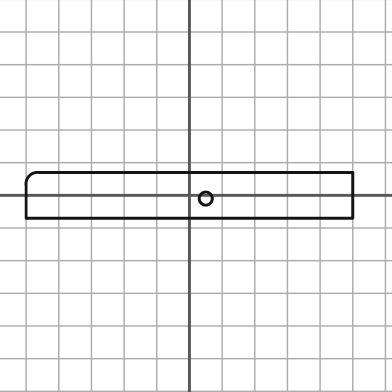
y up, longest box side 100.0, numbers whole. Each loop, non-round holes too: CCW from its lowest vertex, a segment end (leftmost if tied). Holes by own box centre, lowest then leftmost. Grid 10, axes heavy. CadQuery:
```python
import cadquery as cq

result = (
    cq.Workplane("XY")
    .moveTo(-50.0, -7.0)
    .lineTo(50.0, -7.0)
    .lineTo(50.0, 7.0)
    .lineTo(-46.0, 7.0)
    .threePointArc((-49.0, 6.0), (-50.0, 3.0))
    .close()
    .moveTo(5.0, -1.0)
    .circle(2.0)
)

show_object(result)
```